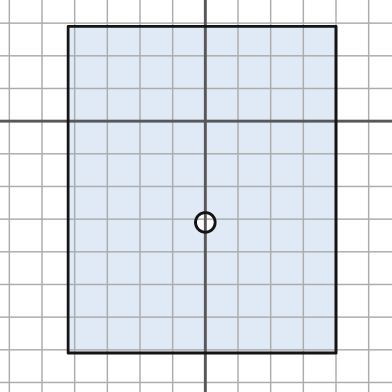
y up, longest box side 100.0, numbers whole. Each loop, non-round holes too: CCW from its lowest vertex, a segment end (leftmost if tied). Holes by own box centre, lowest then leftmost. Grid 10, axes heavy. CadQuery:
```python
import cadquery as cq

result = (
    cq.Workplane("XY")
    .moveTo(-42.0, -71.0)
    .lineTo(40.0, -71.0)
    .lineTo(40.0, 29.0)
    .lineTo(-42.0, 29.0)
    .close()
    .moveTo(0.0, -31.0)
    .circle(3.0)
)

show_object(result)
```